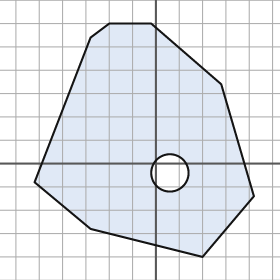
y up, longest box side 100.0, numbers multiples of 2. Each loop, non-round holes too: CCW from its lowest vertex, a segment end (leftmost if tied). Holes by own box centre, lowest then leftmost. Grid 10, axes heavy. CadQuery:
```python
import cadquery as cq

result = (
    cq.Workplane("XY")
    .moveTo(20.0, -40.0)
    .lineTo(42.0, -14.0)
    .lineTo(28.0, 34.0)
    .lineTo(-2.0, 60.0)
    .lineTo(-20.0, 60.0)
    .lineTo(-28.0, 54.0)
    .lineTo(-52.0, -8.0)
    .lineTo(-28.0, -28.0)
    .close()
    .moveTo(6.0, -4.0)
    .circle(8.0)
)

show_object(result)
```